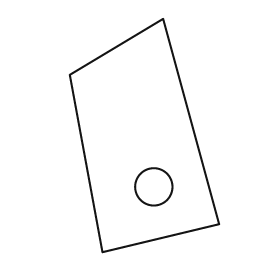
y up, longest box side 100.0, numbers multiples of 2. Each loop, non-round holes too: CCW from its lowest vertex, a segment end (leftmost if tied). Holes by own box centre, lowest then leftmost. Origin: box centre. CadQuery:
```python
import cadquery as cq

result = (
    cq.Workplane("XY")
    .moveTo(-18.0, -50.0)
    .lineTo(32.0, -38.0)
    .lineTo(8.0, 50.0)
    .lineTo(-32.0, 26.0)
    .close()
    .moveTo(4.0, -22.0)
    .circle(8.0)
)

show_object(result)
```